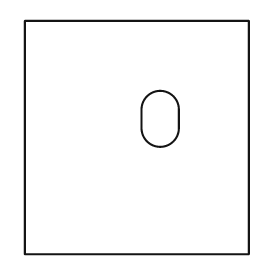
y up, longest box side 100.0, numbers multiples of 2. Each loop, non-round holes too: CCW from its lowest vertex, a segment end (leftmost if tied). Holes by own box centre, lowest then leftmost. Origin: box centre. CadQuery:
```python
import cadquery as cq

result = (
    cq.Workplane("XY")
    .moveTo(-48.0, -50.0)
    .lineTo(48.0, -50.0)
    .lineTo(48.0, 50.0)
    .lineTo(-48.0, 50.0)
    .close()
    .moveTo(2.0, 4.0)
    .threePointArc((10.0, -4.0), (18.0, 4.0))
    .lineTo(18.0, 12.0)
    .threePointArc((10.0, 20.0), (2.0, 12.0))
    .close()
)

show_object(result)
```